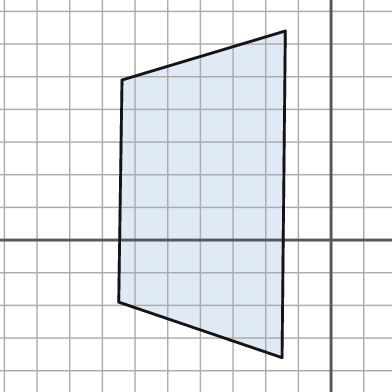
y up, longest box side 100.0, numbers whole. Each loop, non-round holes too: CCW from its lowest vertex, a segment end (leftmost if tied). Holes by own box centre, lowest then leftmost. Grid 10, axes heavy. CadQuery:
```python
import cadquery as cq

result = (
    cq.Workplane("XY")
    .moveTo(-15.0, -36.0)
    .lineTo(-14.0, 64.0)
    .lineTo(-64.0, 49.0)
    .lineTo(-65.0, -19.0)
    .close()
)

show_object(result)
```